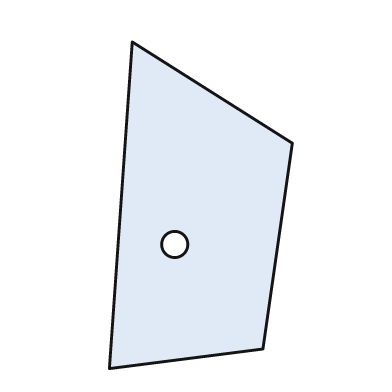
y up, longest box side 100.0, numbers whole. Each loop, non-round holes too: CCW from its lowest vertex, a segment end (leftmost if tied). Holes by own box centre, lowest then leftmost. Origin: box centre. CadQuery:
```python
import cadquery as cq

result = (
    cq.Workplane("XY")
    .moveTo(-28.0, -50.0)
    .lineTo(19.0, -44.0)
    .lineTo(28.0, 19.0)
    .lineTo(-21.0, 50.0)
    .close()
    .moveTo(-8.0, -12.0)
    .circle(4.0)
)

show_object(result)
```